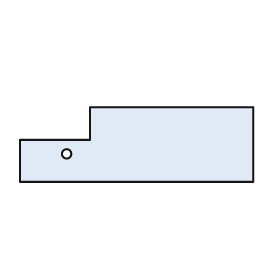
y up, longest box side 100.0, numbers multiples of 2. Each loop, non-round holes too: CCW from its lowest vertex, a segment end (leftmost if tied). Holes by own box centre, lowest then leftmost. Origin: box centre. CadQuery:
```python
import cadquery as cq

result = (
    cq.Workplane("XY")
    .moveTo(-50.0, -16.0)
    .lineTo(50.0, -16.0)
    .lineTo(50.0, 16.0)
    .lineTo(-20.0, 16.0)
    .lineTo(-20.0, 2.0)
    .lineTo(-50.0, 2.0)
    .close()
    .moveTo(-30.0, -4.0)
    .circle(2.0)
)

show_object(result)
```